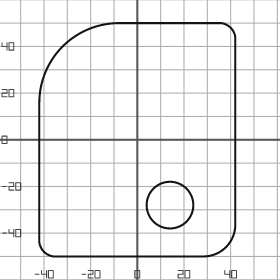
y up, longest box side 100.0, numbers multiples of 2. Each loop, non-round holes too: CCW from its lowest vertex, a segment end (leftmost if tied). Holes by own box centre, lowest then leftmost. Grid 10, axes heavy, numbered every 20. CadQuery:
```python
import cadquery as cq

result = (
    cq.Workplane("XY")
    .moveTo(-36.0, -50.0)
    .lineTo(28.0, -50.0)
    .threePointArc((38.0, -46.0), (42.0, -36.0))
    .lineTo(42.0, 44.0)
    .threePointArc((40.0, 48.0), (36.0, 50.0))
    .lineTo(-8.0, 50.0)
    .threePointArc((-32.0, 40.0), (-42.0, 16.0))
    .lineTo(-42.0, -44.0)
    .threePointArc((-40.0, -48.0), (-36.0, -50.0))
    .close()
    .moveTo(14.0, -28.0)
    .circle(10.0)
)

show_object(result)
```